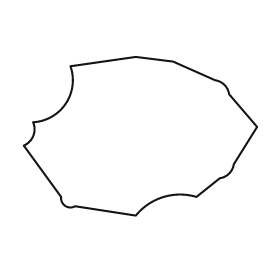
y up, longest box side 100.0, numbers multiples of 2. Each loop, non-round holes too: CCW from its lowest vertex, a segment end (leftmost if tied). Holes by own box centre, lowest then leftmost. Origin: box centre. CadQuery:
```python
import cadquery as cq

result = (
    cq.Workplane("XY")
    .moveTo(-2.0, -34.0)
    .threePointArc((10.0, -26.0), (24.0, -26.0))
    .lineTo(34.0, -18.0)
    .threePointArc((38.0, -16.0), (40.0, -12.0))
    .lineTo(50.0, 4.0)
    .lineTo(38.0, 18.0)
    .threePointArc((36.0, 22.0), (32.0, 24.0))
    .lineTo(14.0, 32.0)
    .lineTo(-2.0, 34.0)
    .lineTo(-30.0, 30.0)
    .threePointArc((-32.0, 14.0), (-46.0, 6.0))
    .threePointArc((-46.0, 0.0), (-50.0, -4.0))
    .lineTo(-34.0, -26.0)
    .threePointArc((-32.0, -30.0), (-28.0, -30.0))
    .close()
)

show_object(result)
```